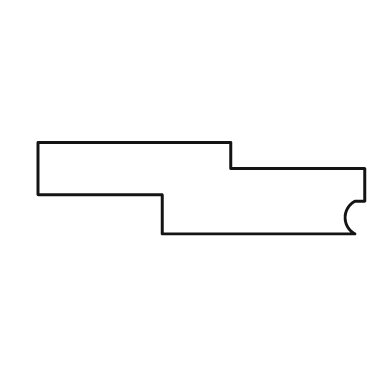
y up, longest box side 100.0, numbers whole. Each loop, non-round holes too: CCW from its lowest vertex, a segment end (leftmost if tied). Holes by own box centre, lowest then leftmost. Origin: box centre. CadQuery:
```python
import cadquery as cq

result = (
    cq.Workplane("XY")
    .moveTo(-12.0, -14.0)
    .lineTo(47.0, -14.0)
    .threePointArc((44.0, -9.0), (47.0, -4.0))
    .lineTo(50.0, -4.0)
    .lineTo(50.0, 6.0)
    .lineTo(9.0, 6.0)
    .lineTo(9.0, 14.0)
    .lineTo(-50.0, 14.0)
    .lineTo(-50.0, -2.0)
    .lineTo(-12.0, -2.0)
    .close()
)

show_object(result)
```